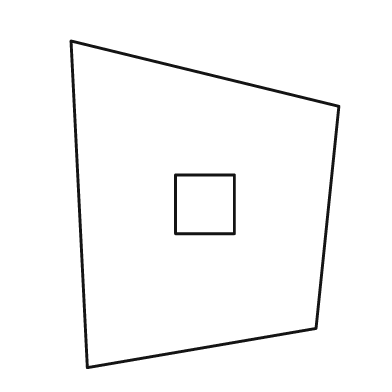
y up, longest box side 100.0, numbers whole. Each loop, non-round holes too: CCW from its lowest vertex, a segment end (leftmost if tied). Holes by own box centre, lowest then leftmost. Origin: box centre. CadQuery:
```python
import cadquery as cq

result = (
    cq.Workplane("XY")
    .moveTo(-36.0, -50.0)
    .lineTo(34.0, -38.0)
    .lineTo(41.0, 30.0)
    .lineTo(-41.0, 50.0)
    .close()
    .moveTo(-9.0, -9.0)
    .lineTo(9.0, -9.0)
    .lineTo(9.0, 9.0)
    .lineTo(-9.0, 9.0)
    .close()
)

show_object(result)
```